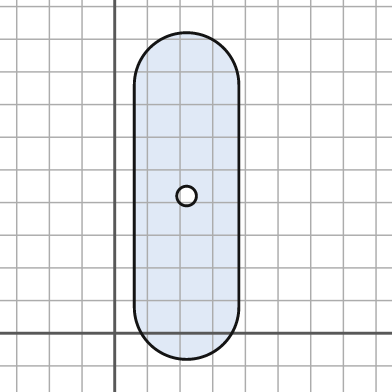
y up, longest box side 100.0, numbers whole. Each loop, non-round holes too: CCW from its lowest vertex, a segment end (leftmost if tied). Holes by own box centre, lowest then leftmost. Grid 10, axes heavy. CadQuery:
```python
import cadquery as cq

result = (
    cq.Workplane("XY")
    .moveTo(6.0, 8.0)
    .threePointArc((22.0, -8.0), (38.0, 8.0))
    .lineTo(38.0, 76.0)
    .threePointArc((22.0, 92.0), (6.0, 76.0))
    .close()
    .moveTo(22.0, 42.0)
    .circle(3.0)
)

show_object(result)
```